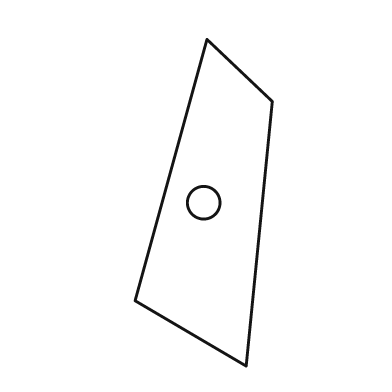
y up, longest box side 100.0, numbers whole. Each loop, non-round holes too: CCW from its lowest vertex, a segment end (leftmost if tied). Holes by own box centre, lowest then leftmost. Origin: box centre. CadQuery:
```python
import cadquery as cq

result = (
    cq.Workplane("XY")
    .moveTo(13.0, -50.0)
    .lineTo(21.0, 31.0)
    .lineTo(1.0, 50.0)
    .lineTo(-21.0, -30.0)
    .close()
    .moveTo(0.0, 0.0)
    .circle(5.0)
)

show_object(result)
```